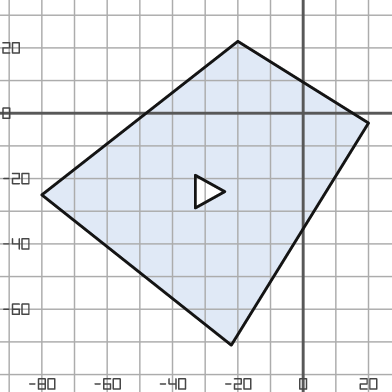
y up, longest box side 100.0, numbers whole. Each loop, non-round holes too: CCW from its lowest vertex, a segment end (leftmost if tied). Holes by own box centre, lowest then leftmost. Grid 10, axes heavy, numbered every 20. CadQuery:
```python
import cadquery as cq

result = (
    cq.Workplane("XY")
    .moveTo(-22.0, -71.0)
    .lineTo(20.0, -3.0)
    .lineTo(-20.0, 22.0)
    .lineTo(-80.0, -25.0)
    .close()
    .moveTo(-33.0, -29.0)
    .lineTo(-24.0, -24.0)
    .lineTo(-33.0, -19.0)
    .close()
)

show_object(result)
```